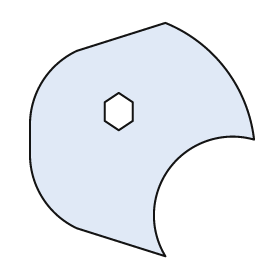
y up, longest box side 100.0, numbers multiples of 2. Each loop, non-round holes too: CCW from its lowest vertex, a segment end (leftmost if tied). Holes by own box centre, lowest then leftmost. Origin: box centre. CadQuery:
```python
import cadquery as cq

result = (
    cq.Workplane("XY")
    .moveTo(10.0, -50.0)
    .threePointArc((12.0, -12.0), (48.0, 0.0))
    .threePointArc((36.0, 30.0), (10.0, 50.0))
    .lineTo(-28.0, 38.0)
    .threePointArc((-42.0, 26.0), (-48.0, 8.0))
    .lineTo(-48.0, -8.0)
    .threePointArc((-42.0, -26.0), (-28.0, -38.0))
    .close()
    .moveTo(-10.0, 4.0)
    .lineTo(-4.0, 8.0)
    .lineTo(-4.0, 16.0)
    .lineTo(-10.0, 20.0)
    .lineTo(-16.0, 16.0)
    .lineTo(-16.0, 8.0)
    .close()
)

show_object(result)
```